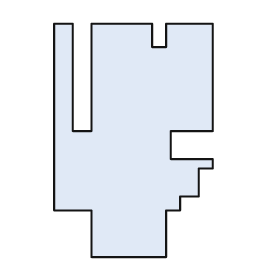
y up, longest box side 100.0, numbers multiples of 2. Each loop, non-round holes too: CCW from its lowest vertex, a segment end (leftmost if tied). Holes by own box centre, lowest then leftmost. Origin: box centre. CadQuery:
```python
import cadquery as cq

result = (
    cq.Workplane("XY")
    .moveTo(-18.0, -50.0)
    .lineTo(14.0, -50.0)
    .lineTo(14.0, -30.0)
    .lineTo(20.0, -30.0)
    .lineTo(20.0, -24.0)
    .lineTo(28.0, -24.0)
    .lineTo(28.0, -12.0)
    .lineTo(34.0, -12.0)
    .lineTo(34.0, -8.0)
    .lineTo(16.0, -8.0)
    .lineTo(16.0, 4.0)
    .lineTo(34.0, 4.0)
    .lineTo(34.0, 50.0)
    .lineTo(14.0, 50.0)
    .lineTo(14.0, 40.0)
    .lineTo(8.0, 40.0)
    .lineTo(8.0, 50.0)
    .lineTo(-18.0, 50.0)
    .lineTo(-18.0, 4.0)
    .lineTo(-26.0, 4.0)
    .lineTo(-26.0, 50.0)
    .lineTo(-34.0, 50.0)
    .lineTo(-34.0, -30.0)
    .lineTo(-18.0, -30.0)
    .close()
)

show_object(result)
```